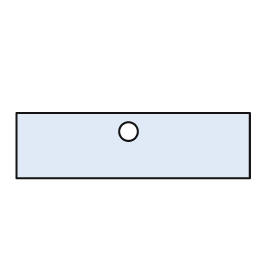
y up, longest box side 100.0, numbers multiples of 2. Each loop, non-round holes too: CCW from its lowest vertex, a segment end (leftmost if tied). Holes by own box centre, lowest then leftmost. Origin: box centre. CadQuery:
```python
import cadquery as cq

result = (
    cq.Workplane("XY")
    .moveTo(-50.0, -14.0)
    .lineTo(50.0, -14.0)
    .lineTo(50.0, 14.0)
    .lineTo(-50.0, 14.0)
    .close()
    .moveTo(-2.0, 6.0)
    .circle(4.0)
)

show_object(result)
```